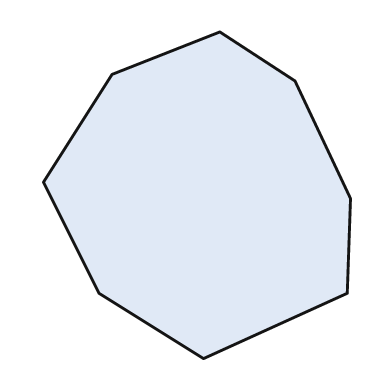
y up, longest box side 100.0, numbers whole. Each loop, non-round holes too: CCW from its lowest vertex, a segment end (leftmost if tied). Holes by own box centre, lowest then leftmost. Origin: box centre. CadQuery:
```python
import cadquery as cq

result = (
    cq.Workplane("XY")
    .moveTo(2.0, -50.0)
    .lineTo(46.0, -30.0)
    .lineTo(47.0, -1.0)
    .lineTo(30.0, 35.0)
    .lineTo(7.0, 50.0)
    .lineTo(-26.0, 37.0)
    .lineTo(-47.0, 4.0)
    .lineTo(-30.0, -30.0)
    .close()
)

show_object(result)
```